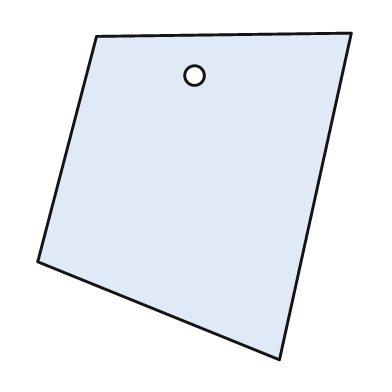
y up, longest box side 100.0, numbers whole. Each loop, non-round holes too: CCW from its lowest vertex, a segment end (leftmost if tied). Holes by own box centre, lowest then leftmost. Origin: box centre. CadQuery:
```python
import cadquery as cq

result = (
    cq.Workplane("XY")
    .moveTo(26.0, -50.0)
    .lineTo(48.0, 50.0)
    .lineTo(-30.0, 49.0)
    .lineTo(-48.0, -20.0)
    .close()
    .moveTo(0.0, 37.0)
    .circle(3.0)
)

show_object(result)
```